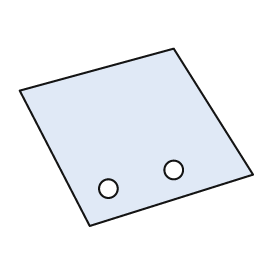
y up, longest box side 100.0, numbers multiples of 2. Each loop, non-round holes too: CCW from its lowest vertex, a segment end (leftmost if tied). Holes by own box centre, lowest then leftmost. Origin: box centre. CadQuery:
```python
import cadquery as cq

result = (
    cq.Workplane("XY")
    .moveTo(-20.0, -38.0)
    .lineTo(50.0, -16.0)
    .lineTo(16.0, 38.0)
    .lineTo(-50.0, 20.0)
    .close()
    .moveTo(-12.0, -22.0)
    .circle(4.0)
    .moveTo(16.0, -14.0)
    .circle(4.0)
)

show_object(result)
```